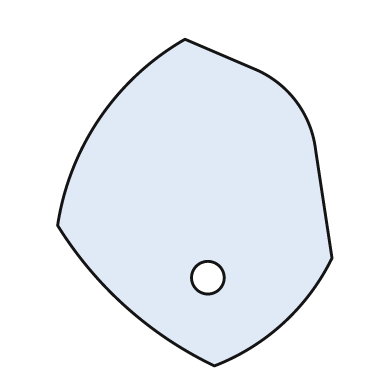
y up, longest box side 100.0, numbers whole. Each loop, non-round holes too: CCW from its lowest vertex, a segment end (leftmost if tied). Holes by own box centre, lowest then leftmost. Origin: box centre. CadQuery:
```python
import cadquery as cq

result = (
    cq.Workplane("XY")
    .moveTo(6.0, -50.0)
    .threePointArc((27.0, -37.0), (42.0, -17.0))
    .lineTo(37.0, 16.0)
    .threePointArc((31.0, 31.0), (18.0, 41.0))
    .lineTo(-3.0, 50.0)
    .threePointArc((-29.0, 26.0), (-42.0, -7.0))
    .threePointArc((-21.0, -32.0), (6.0, -50.0))
    .close()
    .moveTo(4.0, -23.0)
    .circle(5.0)
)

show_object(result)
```